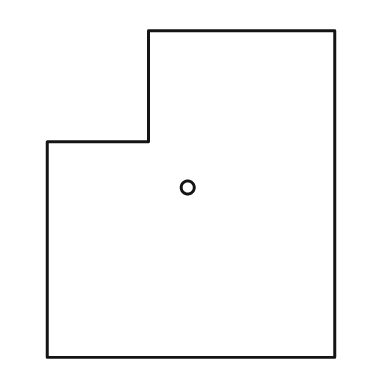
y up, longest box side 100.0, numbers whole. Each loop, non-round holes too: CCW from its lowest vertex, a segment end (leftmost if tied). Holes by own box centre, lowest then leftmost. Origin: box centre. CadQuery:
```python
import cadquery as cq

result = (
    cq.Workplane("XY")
    .moveTo(-44.0, -50.0)
    .lineTo(44.0, -50.0)
    .lineTo(44.0, 50.0)
    .lineTo(-13.0, 50.0)
    .lineTo(-13.0, 16.0)
    .lineTo(-44.0, 16.0)
    .close()
    .moveTo(-1.0, 2.0)
    .circle(2.0)
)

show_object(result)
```